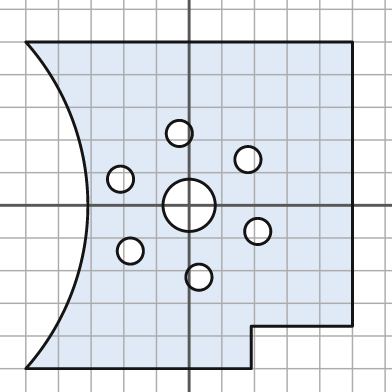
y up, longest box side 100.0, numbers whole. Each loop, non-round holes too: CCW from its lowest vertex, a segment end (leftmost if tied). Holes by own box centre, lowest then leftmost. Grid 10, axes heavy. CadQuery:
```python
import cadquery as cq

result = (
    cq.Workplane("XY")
    .moveTo(-50.0, -50.0)
    .lineTo(19.0, -50.0)
    .lineTo(19.0, -37.0)
    .lineTo(50.0, -37.0)
    .lineTo(50.0, 50.0)
    .lineTo(-50.0, 50.0)
    .threePointArc((-31.0, 0.0), (-50.0, -50.0))
    .close()
    .moveTo(3.0, -22.0)
    .circle(4.0)
    .moveTo(-18.0, -14.0)
    .circle(4.0)
    .moveTo(21.0, -8.0)
    .circle(4.0)
    .moveTo(0.0, 0.0)
    .circle(8.0)
    .moveTo(-21.0, 8.0)
    .circle(4.0)
    .moveTo(18.0, 14.0)
    .circle(4.0)
    .moveTo(-3.0, 22.0)
    .circle(4.0)
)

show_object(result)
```